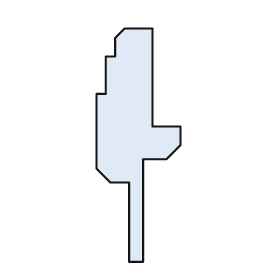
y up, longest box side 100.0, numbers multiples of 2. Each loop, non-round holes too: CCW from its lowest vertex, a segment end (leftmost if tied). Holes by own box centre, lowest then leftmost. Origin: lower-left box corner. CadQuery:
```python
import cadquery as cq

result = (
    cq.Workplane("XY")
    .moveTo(14.0, 0.0)
    .lineTo(20.0, 0.0)
    .lineTo(20.0, 44.0)
    .lineTo(30.0, 44.0)
    .lineTo(36.0, 50.0)
    .lineTo(36.0, 58.0)
    .lineTo(24.0, 58.0)
    .lineTo(24.0, 100.0)
    .lineTo(12.0, 100.0)
    .lineTo(8.0, 96.0)
    .lineTo(8.0, 88.0)
    .lineTo(4.0, 88.0)
    .lineTo(4.0, 72.0)
    .lineTo(0.0, 72.0)
    .lineTo(0.0, 40.0)
    .lineTo(6.0, 34.0)
    .lineTo(14.0, 34.0)
    .close()
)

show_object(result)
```